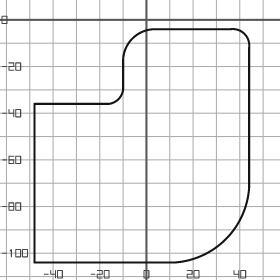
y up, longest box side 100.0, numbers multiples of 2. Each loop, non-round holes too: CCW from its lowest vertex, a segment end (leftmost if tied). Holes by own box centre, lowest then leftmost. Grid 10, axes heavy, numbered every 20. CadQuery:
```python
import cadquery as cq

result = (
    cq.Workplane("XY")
    .moveTo(-48.0, -104.0)
    .lineTo(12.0, -104.0)
    .threePointArc((34.0, -94.0), (44.0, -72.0))
    .lineTo(44.0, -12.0)
    .threePointArc((42.0, -6.0), (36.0, -4.0))
    .lineTo(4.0, -4.0)
    .threePointArc((-6.0, -8.0), (-10.0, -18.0))
    .lineTo(-10.0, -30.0)
    .threePointArc((-12.0, -34.0), (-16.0, -36.0))
    .lineTo(-48.0, -36.0)
    .close()
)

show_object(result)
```